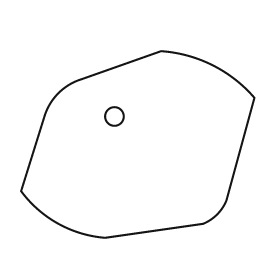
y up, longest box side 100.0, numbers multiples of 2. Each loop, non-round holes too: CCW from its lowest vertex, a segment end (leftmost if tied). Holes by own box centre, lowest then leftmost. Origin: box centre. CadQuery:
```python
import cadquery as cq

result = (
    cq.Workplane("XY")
    .moveTo(-14.0, -40.0)
    .lineTo(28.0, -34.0)
    .threePointArc((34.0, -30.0), (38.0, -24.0))
    .lineTo(50.0, 20.0)
    .threePointArc((32.0, 34.0), (10.0, 40.0))
    .lineTo(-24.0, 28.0)
    .threePointArc((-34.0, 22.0), (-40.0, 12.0))
    .lineTo(-50.0, -20.0)
    .threePointArc((-34.0, -34.0), (-14.0, -40.0))
    .close()
    .moveTo(-10.0, 12.0)
    .circle(4.0)
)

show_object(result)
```